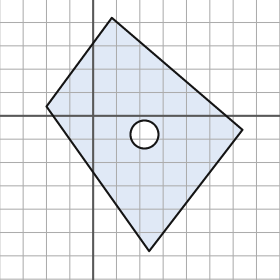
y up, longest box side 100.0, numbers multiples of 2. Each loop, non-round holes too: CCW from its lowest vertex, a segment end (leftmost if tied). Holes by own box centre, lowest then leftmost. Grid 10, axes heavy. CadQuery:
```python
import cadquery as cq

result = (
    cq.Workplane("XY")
    .moveTo(24.0, -58.0)
    .lineTo(64.0, -6.0)
    .lineTo(8.0, 42.0)
    .lineTo(-20.0, 4.0)
    .close()
    .moveTo(22.0, -8.0)
    .circle(6.0)
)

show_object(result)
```